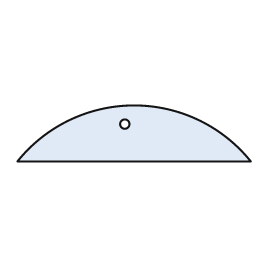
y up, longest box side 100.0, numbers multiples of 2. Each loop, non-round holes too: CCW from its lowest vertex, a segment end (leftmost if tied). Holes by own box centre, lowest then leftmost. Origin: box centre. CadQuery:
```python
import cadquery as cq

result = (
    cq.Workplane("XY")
    .moveTo(-50.0, -12.0)
    .lineTo(50.0, -12.0)
    .threePointArc((0.0, 12.0), (-50.0, -12.0))
    .close()
    .moveTo(-4.0, 4.0)
    .circle(2.0)
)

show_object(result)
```